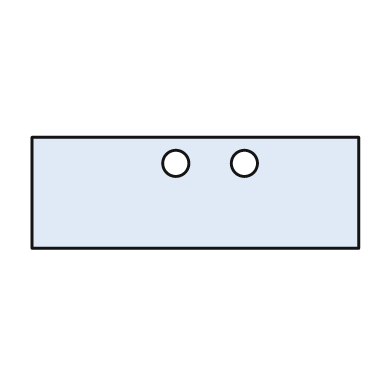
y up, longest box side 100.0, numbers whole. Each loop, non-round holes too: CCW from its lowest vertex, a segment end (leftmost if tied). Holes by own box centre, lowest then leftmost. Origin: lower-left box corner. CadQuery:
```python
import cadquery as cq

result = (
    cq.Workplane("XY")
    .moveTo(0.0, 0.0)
    .lineTo(100.0, 0.0)
    .lineTo(100.0, 34.0)
    .lineTo(0.0, 34.0)
    .close()
    .moveTo(44.0, 26.0)
    .circle(4.0)
    .moveTo(65.0, 26.0)
    .circle(4.0)
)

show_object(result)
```